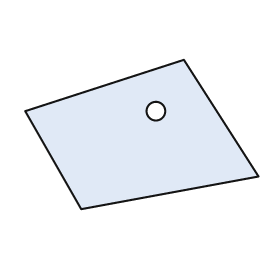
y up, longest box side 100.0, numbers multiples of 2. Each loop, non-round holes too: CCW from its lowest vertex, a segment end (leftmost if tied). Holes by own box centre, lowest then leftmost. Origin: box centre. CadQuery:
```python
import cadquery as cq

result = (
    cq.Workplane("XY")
    .moveTo(-26.0, -32.0)
    .lineTo(50.0, -18.0)
    .lineTo(18.0, 32.0)
    .lineTo(-50.0, 10.0)
    .close()
    .moveTo(6.0, 10.0)
    .circle(4.0)
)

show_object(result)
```